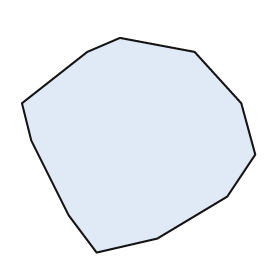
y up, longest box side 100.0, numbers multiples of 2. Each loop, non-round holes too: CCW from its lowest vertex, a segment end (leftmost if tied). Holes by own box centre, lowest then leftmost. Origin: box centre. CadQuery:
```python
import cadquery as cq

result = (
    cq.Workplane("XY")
    .moveTo(-18.0, -46.0)
    .lineTo(8.0, -40.0)
    .lineTo(38.0, -22.0)
    .lineTo(50.0, -4.0)
    .lineTo(44.0, 18.0)
    .lineTo(24.0, 40.0)
    .lineTo(-8.0, 46.0)
    .lineTo(-22.0, 40.0)
    .lineTo(-50.0, 18.0)
    .lineTo(-46.0, 2.0)
    .lineTo(-30.0, -30.0)
    .close()
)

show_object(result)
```